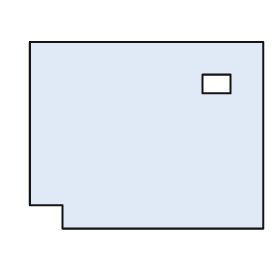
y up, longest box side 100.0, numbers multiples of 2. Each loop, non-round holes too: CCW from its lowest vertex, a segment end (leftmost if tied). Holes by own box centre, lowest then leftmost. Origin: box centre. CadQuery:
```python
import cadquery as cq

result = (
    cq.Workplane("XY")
    .moveTo(-36.0, -40.0)
    .lineTo(50.0, -40.0)
    .lineTo(50.0, 40.0)
    .lineTo(-50.0, 40.0)
    .lineTo(-50.0, -30.0)
    .lineTo(-36.0, -30.0)
    .close()
    .moveTo(24.0, 18.0)
    .lineTo(36.0, 18.0)
    .lineTo(36.0, 26.0)
    .lineTo(24.0, 26.0)
    .close()
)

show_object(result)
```